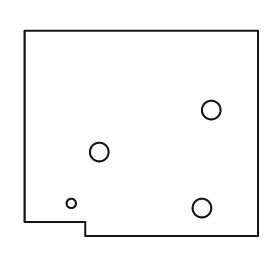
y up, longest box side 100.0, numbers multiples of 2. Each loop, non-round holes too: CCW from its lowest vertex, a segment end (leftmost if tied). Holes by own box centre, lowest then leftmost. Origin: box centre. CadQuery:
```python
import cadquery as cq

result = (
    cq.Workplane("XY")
    .moveTo(-24.0, -44.0)
    .lineTo(50.0, -44.0)
    .lineTo(50.0, 44.0)
    .lineTo(-50.0, 44.0)
    .lineTo(-50.0, -38.0)
    .lineTo(-24.0, -38.0)
    .close()
    .moveTo(26.0, -32.0)
    .circle(4.0)
    .moveTo(-30.0, -30.0)
    .circle(2.0)
    .moveTo(-18.0, -8.0)
    .circle(4.0)
    .moveTo(30.0, 10.0)
    .circle(4.0)
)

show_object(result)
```